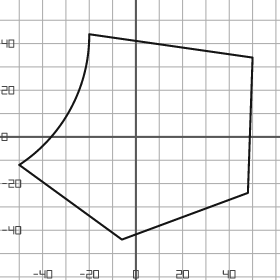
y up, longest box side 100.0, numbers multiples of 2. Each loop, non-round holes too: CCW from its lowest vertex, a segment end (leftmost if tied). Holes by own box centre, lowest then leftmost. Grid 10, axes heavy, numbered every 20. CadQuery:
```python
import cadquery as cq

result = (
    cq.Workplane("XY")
    .moveTo(-6.0, -44.0)
    .lineTo(48.0, -24.0)
    .lineTo(50.0, 34.0)
    .lineTo(-20.0, 44.0)
    .threePointArc((-28.0, 12.0), (-50.0, -12.0))
    .close()
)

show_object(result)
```